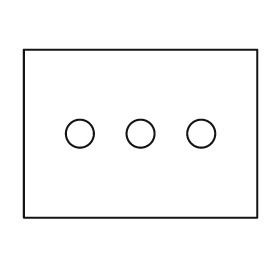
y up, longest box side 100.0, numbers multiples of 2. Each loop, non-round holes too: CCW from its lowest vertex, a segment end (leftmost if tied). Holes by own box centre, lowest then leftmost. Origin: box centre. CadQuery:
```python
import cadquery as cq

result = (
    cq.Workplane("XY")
    .moveTo(-50.0, -36.0)
    .lineTo(50.0, -36.0)
    .lineTo(50.0, 36.0)
    .lineTo(-50.0, 36.0)
    .close()
    .moveTo(-26.0, 0.0)
    .circle(6.0)
    .moveTo(0.0, 0.0)
    .circle(6.0)
    .moveTo(26.0, 0.0)
    .circle(6.0)
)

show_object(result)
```